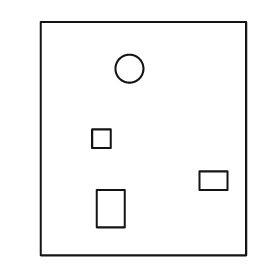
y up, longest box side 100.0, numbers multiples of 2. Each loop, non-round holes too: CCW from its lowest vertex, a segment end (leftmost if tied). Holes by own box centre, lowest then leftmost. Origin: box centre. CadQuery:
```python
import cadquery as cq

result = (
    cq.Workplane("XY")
    .moveTo(-44.0, -50.0)
    .lineTo(44.0, -50.0)
    .lineTo(44.0, 50.0)
    .lineTo(-44.0, 50.0)
    .close()
    .moveTo(-20.0, -38.0)
    .lineTo(-8.0, -38.0)
    .lineTo(-8.0, -22.0)
    .lineTo(-20.0, -22.0)
    .close()
    .moveTo(24.0, -22.0)
    .lineTo(36.0, -22.0)
    .lineTo(36.0, -14.0)
    .lineTo(24.0, -14.0)
    .close()
    .moveTo(-22.0, -4.0)
    .lineTo(-14.0, -4.0)
    .lineTo(-14.0, 4.0)
    .lineTo(-22.0, 4.0)
    .close()
    .moveTo(-6.0, 30.0)
    .circle(6.0)
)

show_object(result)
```